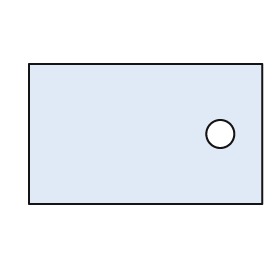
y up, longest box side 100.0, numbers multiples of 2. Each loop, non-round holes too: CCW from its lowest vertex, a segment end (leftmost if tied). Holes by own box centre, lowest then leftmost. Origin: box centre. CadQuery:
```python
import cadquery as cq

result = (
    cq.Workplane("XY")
    .moveTo(-50.0, -30.0)
    .lineTo(50.0, -30.0)
    .lineTo(50.0, 30.0)
    .lineTo(-50.0, 30.0)
    .close()
    .moveTo(32.0, 0.0)
    .circle(6.0)
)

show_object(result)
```